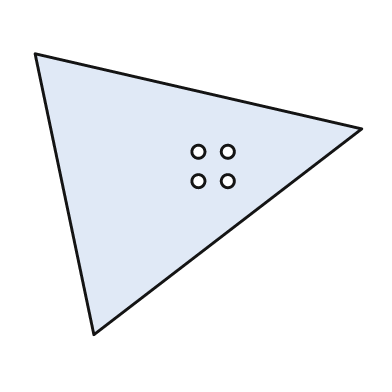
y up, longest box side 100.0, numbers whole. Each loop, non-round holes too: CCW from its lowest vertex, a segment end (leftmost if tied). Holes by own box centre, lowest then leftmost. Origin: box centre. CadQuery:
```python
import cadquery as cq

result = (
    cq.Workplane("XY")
    .moveTo(-32.0, -43.0)
    .lineTo(50.0, 20.0)
    .lineTo(-50.0, 43.0)
    .close()
    .moveTo(0.0, 4.0)
    .circle(2.0)
    .moveTo(9.0, 4.0)
    .circle(2.0)
    .moveTo(0.0, 13.0)
    .circle(2.0)
    .moveTo(9.0, 13.0)
    .circle(2.0)
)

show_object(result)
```